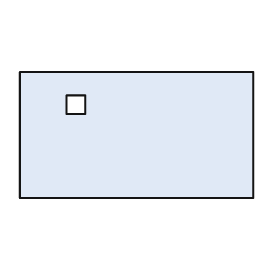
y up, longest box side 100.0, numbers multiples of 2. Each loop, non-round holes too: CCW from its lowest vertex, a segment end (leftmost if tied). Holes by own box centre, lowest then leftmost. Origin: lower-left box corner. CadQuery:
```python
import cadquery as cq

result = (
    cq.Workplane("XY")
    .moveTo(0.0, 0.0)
    .lineTo(100.0, 0.0)
    .lineTo(100.0, 54.0)
    .lineTo(0.0, 54.0)
    .close()
    .moveTo(20.0, 36.0)
    .lineTo(28.0, 36.0)
    .lineTo(28.0, 44.0)
    .lineTo(20.0, 44.0)
    .close()
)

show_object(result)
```